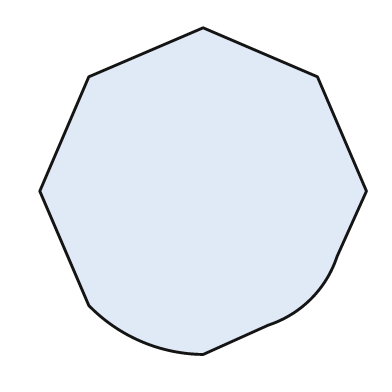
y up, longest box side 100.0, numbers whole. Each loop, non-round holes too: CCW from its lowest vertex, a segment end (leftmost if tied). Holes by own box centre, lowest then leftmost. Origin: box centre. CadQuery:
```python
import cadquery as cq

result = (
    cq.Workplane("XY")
    .moveTo(0.0, -50.0)
    .lineTo(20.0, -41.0)
    .threePointArc((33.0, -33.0), (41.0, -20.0))
    .lineTo(50.0, 0.0)
    .lineTo(35.0, 35.0)
    .lineTo(0.0, 50.0)
    .lineTo(-35.0, 35.0)
    .lineTo(-50.0, 0.0)
    .lineTo(-35.0, -35.0)
    .threePointArc((-19.0, -46.0), (0.0, -50.0))
    .close()
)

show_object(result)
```